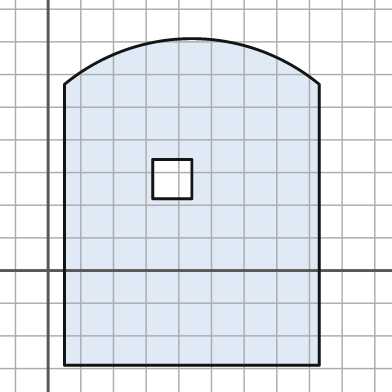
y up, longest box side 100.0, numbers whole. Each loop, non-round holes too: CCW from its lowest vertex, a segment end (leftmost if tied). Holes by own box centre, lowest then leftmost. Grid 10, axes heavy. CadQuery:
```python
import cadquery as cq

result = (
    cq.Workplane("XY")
    .moveTo(5.0, -29.0)
    .lineTo(83.0, -29.0)
    .lineTo(83.0, 57.0)
    .threePointArc((44.0, 71.0), (5.0, 57.0))
    .close()
    .moveTo(32.0, 22.0)
    .lineTo(44.0, 22.0)
    .lineTo(44.0, 34.0)
    .lineTo(32.0, 34.0)
    .close()
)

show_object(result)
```